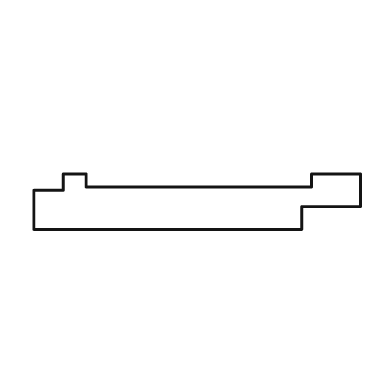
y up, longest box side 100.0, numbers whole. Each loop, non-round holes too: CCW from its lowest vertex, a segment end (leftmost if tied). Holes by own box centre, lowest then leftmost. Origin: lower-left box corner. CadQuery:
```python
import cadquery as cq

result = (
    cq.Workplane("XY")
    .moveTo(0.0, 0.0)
    .lineTo(82.0, 0.0)
    .lineTo(82.0, 7.0)
    .lineTo(100.0, 7.0)
    .lineTo(100.0, 17.0)
    .lineTo(85.0, 17.0)
    .lineTo(85.0, 13.0)
    .lineTo(16.0, 13.0)
    .lineTo(16.0, 17.0)
    .lineTo(9.0, 17.0)
    .lineTo(9.0, 12.0)
    .lineTo(0.0, 12.0)
    .close()
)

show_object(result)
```